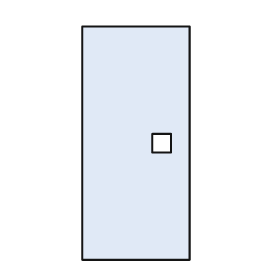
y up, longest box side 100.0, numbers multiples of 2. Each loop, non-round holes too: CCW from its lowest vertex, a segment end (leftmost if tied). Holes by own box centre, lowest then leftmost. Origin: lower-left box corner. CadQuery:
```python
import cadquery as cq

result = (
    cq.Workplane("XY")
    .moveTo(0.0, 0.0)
    .lineTo(46.0, 0.0)
    .lineTo(46.0, 100.0)
    .lineTo(0.0, 100.0)
    .close()
    .moveTo(30.0, 46.0)
    .lineTo(38.0, 46.0)
    .lineTo(38.0, 54.0)
    .lineTo(30.0, 54.0)
    .close()
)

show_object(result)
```